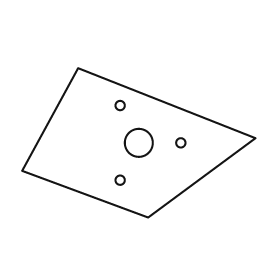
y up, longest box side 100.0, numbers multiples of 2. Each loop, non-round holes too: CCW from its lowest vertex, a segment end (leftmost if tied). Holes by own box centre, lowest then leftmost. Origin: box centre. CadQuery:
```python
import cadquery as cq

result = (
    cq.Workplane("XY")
    .moveTo(4.0, -32.0)
    .lineTo(50.0, 2.0)
    .lineTo(-26.0, 32.0)
    .lineTo(-50.0, -12.0)
    .close()
    .moveTo(-8.0, -16.0)
    .circle(2.0)
    .moveTo(0.0, 0.0)
    .circle(6.0)
    .moveTo(18.0, 0.0)
    .circle(2.0)
    .moveTo(-8.0, 16.0)
    .circle(2.0)
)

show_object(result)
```